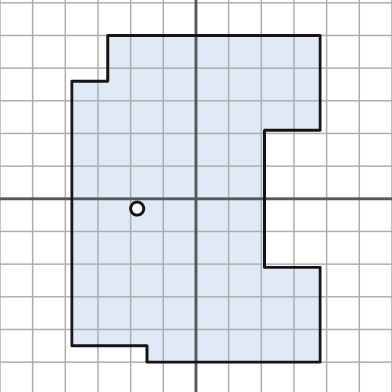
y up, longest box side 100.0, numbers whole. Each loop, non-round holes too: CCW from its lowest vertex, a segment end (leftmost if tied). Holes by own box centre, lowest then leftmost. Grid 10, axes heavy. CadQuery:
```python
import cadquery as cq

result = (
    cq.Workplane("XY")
    .moveTo(-15.0, -50.0)
    .lineTo(38.0, -50.0)
    .lineTo(38.0, -21.0)
    .lineTo(21.0, -21.0)
    .lineTo(21.0, 21.0)
    .lineTo(38.0, 21.0)
    .lineTo(38.0, 50.0)
    .lineTo(-27.0, 50.0)
    .lineTo(-27.0, 36.0)
    .lineTo(-38.0, 36.0)
    .lineTo(-38.0, -45.0)
    .lineTo(-15.0, -45.0)
    .close()
    .moveTo(-18.0, -3.0)
    .circle(2.0)
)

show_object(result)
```